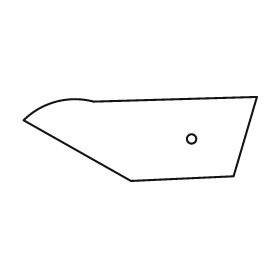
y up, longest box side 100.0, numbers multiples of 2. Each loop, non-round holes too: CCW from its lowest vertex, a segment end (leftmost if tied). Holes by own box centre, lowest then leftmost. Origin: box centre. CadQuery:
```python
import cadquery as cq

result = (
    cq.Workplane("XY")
    .moveTo(-4.0, -18.0)
    .lineTo(40.0, -16.0)
    .lineTo(50.0, 18.0)
    .lineTo(-20.0, 16.0)
    .threePointArc((-36.0, 16.0), (-50.0, 8.0))
    .close()
    .moveTo(22.0, 0.0)
    .circle(2.0)
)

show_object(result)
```